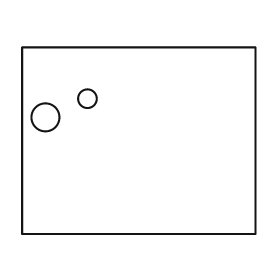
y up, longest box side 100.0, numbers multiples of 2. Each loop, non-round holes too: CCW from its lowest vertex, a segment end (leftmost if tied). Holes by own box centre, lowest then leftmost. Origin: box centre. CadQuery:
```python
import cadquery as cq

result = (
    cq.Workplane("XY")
    .moveTo(-50.0, -40.0)
    .lineTo(50.0, -40.0)
    .lineTo(50.0, 40.0)
    .lineTo(-50.0, 40.0)
    .close()
    .moveTo(-40.0, 10.0)
    .circle(6.0)
    .moveTo(-22.0, 18.0)
    .circle(4.0)
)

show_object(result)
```